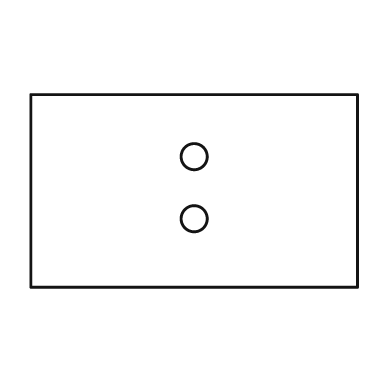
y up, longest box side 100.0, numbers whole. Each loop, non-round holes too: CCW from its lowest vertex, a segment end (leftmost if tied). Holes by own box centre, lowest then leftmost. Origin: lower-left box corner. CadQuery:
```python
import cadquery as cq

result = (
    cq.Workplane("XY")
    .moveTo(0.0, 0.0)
    .lineTo(100.0, 0.0)
    .lineTo(100.0, 59.0)
    .lineTo(0.0, 59.0)
    .close()
    .moveTo(50.0, 21.0)
    .circle(4.0)
    .moveTo(50.0, 40.0)
    .circle(4.0)
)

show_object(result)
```